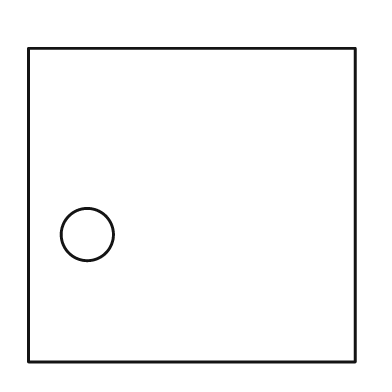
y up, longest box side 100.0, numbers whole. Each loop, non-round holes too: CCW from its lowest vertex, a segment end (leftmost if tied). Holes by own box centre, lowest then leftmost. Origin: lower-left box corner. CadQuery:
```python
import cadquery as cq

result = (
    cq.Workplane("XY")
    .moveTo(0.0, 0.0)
    .lineTo(100.0, 0.0)
    .lineTo(100.0, 96.0)
    .lineTo(0.0, 96.0)
    .close()
    .moveTo(18.0, 39.0)
    .circle(8.0)
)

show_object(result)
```